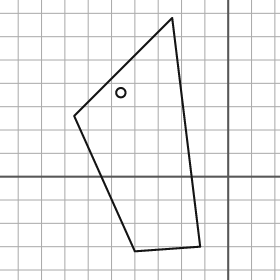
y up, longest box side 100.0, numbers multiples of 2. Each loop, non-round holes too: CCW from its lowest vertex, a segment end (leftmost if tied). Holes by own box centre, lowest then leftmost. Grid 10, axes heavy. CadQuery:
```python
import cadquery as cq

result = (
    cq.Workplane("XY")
    .moveTo(-40.0, -32.0)
    .lineTo(-12.0, -30.0)
    .lineTo(-24.0, 68.0)
    .lineTo(-66.0, 26.0)
    .close()
    .moveTo(-46.0, 36.0)
    .circle(2.0)
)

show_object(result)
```